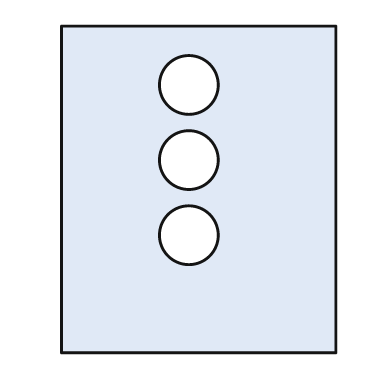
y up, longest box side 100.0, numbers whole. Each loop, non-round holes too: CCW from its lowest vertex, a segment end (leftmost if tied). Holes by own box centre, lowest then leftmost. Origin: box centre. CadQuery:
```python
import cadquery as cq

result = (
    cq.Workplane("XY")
    .moveTo(-42.0, -50.0)
    .lineTo(42.0, -50.0)
    .lineTo(42.0, 50.0)
    .lineTo(-42.0, 50.0)
    .close()
    .moveTo(-3.0, -14.0)
    .circle(9.0)
    .moveTo(-3.0, 9.0)
    .circle(9.0)
    .moveTo(-3.0, 32.0)
    .circle(9.0)
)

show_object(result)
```